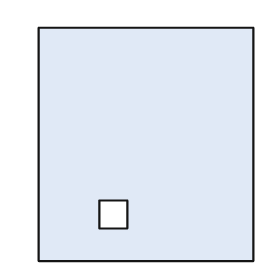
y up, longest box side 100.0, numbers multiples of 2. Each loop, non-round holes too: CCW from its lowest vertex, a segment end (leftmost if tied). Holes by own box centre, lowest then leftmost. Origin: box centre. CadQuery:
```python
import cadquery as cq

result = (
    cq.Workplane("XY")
    .moveTo(-46.0, -50.0)
    .lineTo(46.0, -50.0)
    .lineTo(46.0, 50.0)
    .lineTo(-46.0, 50.0)
    .close()
    .moveTo(-20.0, -36.0)
    .lineTo(-8.0, -36.0)
    .lineTo(-8.0, -24.0)
    .lineTo(-20.0, -24.0)
    .close()
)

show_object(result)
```